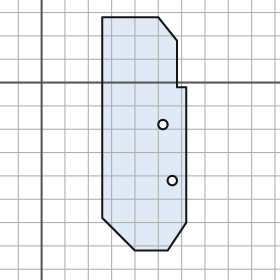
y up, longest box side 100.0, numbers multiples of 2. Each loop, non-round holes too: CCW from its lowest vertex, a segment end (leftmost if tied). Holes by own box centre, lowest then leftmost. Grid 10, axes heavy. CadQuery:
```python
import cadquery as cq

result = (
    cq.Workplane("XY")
    .moveTo(40.0, -72.0)
    .lineTo(54.0, -72.0)
    .lineTo(62.0, -60.0)
    .lineTo(62.0, -2.0)
    .lineTo(58.0, -2.0)
    .lineTo(58.0, 18.0)
    .lineTo(50.0, 28.0)
    .lineTo(26.0, 28.0)
    .lineTo(26.0, -58.0)
    .close()
    .moveTo(56.0, -42.0)
    .circle(2.0)
    .moveTo(52.0, -18.0)
    .circle(2.0)
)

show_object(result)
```